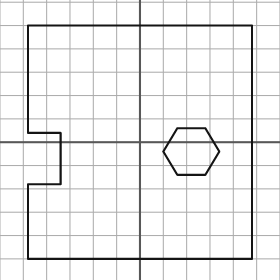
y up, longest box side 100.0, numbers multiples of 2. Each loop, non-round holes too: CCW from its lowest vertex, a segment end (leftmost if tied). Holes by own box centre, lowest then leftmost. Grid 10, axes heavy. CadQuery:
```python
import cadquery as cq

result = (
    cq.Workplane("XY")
    .moveTo(-48.0, -50.0)
    .lineTo(48.0, -50.0)
    .lineTo(48.0, 50.0)
    .lineTo(-48.0, 50.0)
    .lineTo(-48.0, 4.0)
    .lineTo(-34.0, 4.0)
    .lineTo(-34.0, -18.0)
    .lineTo(-48.0, -18.0)
    .close()
    .moveTo(16.0, -14.0)
    .lineTo(28.0, -14.0)
    .lineTo(34.0, -4.0)
    .lineTo(28.0, 6.0)
    .lineTo(16.0, 6.0)
    .lineTo(10.0, -4.0)
    .close()
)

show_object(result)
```